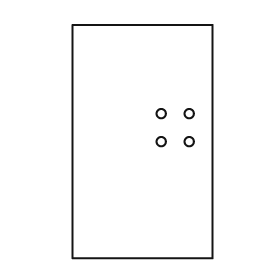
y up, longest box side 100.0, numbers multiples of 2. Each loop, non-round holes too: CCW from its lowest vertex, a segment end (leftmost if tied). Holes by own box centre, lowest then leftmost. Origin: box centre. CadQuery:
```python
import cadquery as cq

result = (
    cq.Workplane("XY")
    .moveTo(-30.0, -50.0)
    .lineTo(30.0, -50.0)
    .lineTo(30.0, 50.0)
    .lineTo(-30.0, 50.0)
    .close()
    .moveTo(8.0, 0.0)
    .circle(2.0)
    .moveTo(20.0, 0.0)
    .circle(2.0)
    .moveTo(8.0, 12.0)
    .circle(2.0)
    .moveTo(20.0, 12.0)
    .circle(2.0)
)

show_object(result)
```